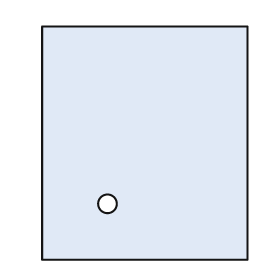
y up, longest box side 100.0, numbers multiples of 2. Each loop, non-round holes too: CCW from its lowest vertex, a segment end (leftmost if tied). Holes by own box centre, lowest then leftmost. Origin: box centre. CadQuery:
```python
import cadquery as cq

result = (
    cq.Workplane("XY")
    .moveTo(-44.0, -50.0)
    .lineTo(44.0, -50.0)
    .lineTo(44.0, 50.0)
    .lineTo(-44.0, 50.0)
    .close()
    .moveTo(-16.0, -26.0)
    .circle(4.0)
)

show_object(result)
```